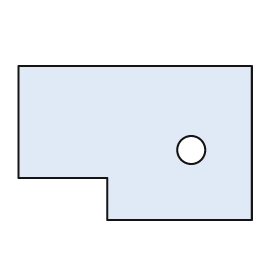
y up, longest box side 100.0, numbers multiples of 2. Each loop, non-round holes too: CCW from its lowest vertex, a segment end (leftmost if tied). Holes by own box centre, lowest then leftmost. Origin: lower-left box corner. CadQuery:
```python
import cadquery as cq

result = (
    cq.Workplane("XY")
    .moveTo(38.0, 0.0)
    .lineTo(100.0, 0.0)
    .lineTo(100.0, 66.0)
    .lineTo(0.0, 66.0)
    .lineTo(0.0, 18.0)
    .lineTo(38.0, 18.0)
    .close()
    .moveTo(74.0, 30.0)
    .circle(6.0)
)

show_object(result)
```